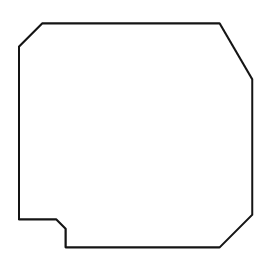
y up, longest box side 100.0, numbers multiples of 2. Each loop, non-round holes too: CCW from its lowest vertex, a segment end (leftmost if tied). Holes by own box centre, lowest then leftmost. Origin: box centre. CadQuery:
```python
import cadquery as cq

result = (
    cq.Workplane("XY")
    .moveTo(-30.0, -48.0)
    .lineTo(36.0, -48.0)
    .lineTo(50.0, -34.0)
    .lineTo(50.0, 24.0)
    .lineTo(36.0, 48.0)
    .lineTo(-40.0, 48.0)
    .lineTo(-50.0, 38.0)
    .lineTo(-50.0, -36.0)
    .lineTo(-34.0, -36.0)
    .lineTo(-30.0, -40.0)
    .close()
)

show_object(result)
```